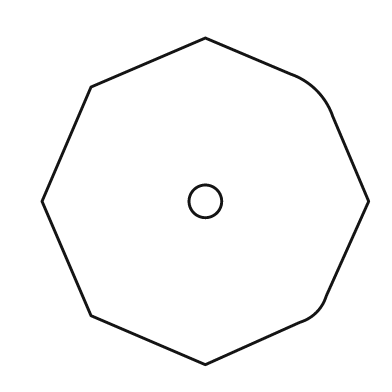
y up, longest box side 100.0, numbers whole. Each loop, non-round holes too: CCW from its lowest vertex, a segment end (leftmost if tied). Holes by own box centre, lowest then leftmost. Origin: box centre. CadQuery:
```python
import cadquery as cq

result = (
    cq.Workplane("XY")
    .moveTo(0.0, -50.0)
    .lineTo(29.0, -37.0)
    .threePointArc((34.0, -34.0), (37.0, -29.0))
    .lineTo(50.0, 0.0)
    .lineTo(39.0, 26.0)
    .threePointArc((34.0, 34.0), (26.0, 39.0))
    .lineTo(0.0, 50.0)
    .lineTo(-35.0, 35.0)
    .lineTo(-50.0, 0.0)
    .lineTo(-35.0, -35.0)
    .close()
    .moveTo(0.0, 0.0)
    .circle(5.0)
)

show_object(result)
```